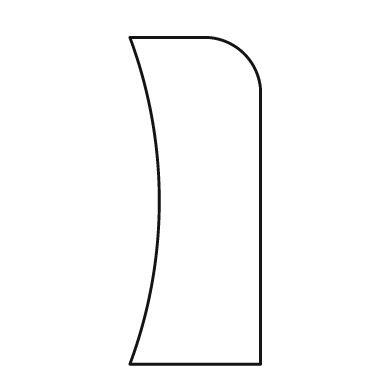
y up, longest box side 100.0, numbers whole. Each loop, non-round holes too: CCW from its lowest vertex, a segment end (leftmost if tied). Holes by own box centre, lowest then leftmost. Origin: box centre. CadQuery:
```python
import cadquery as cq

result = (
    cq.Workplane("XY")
    .moveTo(-20.0, -50.0)
    .lineTo(20.0, -50.0)
    .lineTo(20.0, 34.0)
    .threePointArc((15.0, 45.0), (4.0, 50.0))
    .lineTo(-20.0, 50.0)
    .threePointArc((-11.0, 0.0), (-20.0, -50.0))
    .close()
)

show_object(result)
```